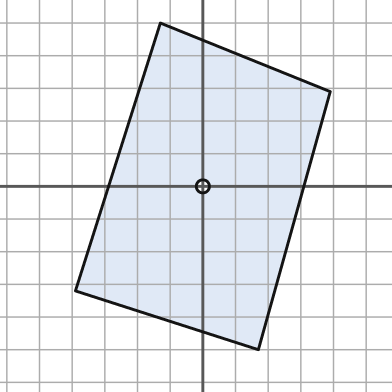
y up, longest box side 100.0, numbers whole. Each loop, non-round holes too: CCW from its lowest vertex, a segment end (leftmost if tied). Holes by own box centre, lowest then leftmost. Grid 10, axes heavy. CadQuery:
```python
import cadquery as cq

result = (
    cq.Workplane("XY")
    .moveTo(17.0, -50.0)
    .lineTo(39.0, 29.0)
    .lineTo(-13.0, 50.0)
    .lineTo(-39.0, -32.0)
    .close()
    .moveTo(0.0, 0.0)
    .circle(2.0)
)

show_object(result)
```